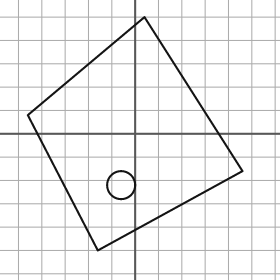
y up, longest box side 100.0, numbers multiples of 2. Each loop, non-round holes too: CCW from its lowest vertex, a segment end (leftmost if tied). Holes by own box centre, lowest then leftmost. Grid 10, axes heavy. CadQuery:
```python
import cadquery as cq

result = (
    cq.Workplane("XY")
    .moveTo(-16.0, -50.0)
    .lineTo(46.0, -16.0)
    .lineTo(4.0, 50.0)
    .lineTo(-46.0, 8.0)
    .close()
    .moveTo(-6.0, -22.0)
    .circle(6.0)
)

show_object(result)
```